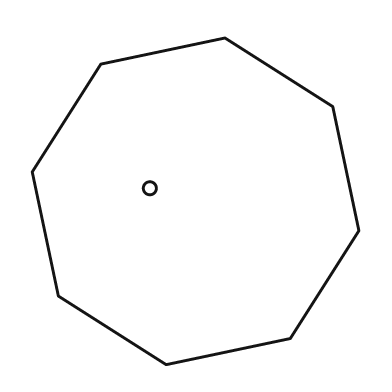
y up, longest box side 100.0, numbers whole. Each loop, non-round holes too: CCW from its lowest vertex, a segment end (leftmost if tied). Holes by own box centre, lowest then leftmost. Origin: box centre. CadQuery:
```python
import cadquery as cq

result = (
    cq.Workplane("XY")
    .moveTo(-9.0, -50.0)
    .lineTo(29.0, -42.0)
    .lineTo(50.0, -9.0)
    .lineTo(42.0, 29.0)
    .lineTo(9.0, 50.0)
    .lineTo(-29.0, 42.0)
    .lineTo(-50.0, 9.0)
    .lineTo(-42.0, -29.0)
    .close()
    .moveTo(-14.0, 4.0)
    .circle(2.0)
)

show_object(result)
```